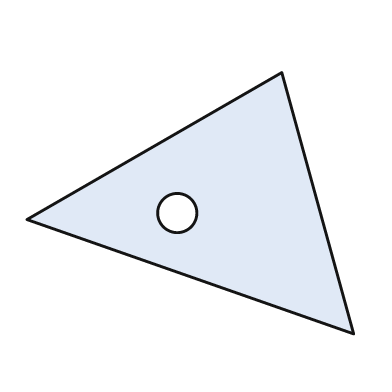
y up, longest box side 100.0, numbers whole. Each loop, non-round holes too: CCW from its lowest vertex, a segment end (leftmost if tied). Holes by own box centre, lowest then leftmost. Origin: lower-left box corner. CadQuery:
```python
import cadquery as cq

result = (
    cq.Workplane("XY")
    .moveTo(100.0, 0.0)
    .lineTo(78.0, 80.0)
    .lineTo(0.0, 35.0)
    .close()
    .moveTo(46.0, 37.0)
    .circle(6.0)
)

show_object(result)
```